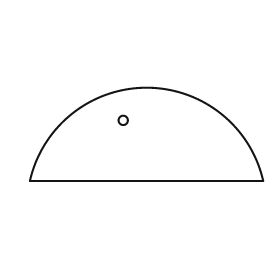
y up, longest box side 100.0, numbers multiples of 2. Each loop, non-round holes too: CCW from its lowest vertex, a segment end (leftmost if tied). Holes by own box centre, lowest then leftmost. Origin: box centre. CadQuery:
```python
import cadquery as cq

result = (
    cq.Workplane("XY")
    .moveTo(-50.0, -20.0)
    .lineTo(50.0, -20.0)
    .threePointArc((0.0, 20.0), (-50.0, -20.0))
    .close()
    .moveTo(-10.0, 6.0)
    .circle(2.0)
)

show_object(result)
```